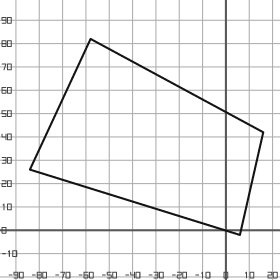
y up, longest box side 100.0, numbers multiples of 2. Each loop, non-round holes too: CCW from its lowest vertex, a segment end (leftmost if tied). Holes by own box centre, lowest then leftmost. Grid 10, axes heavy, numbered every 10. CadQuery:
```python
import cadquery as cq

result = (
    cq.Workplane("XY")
    .moveTo(6.0, -2.0)
    .lineTo(16.0, 42.0)
    .lineTo(-58.0, 82.0)
    .lineTo(-84.0, 26.0)
    .close()
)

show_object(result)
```